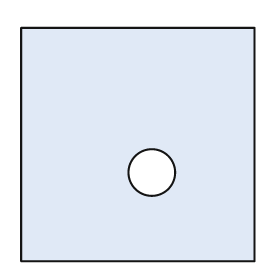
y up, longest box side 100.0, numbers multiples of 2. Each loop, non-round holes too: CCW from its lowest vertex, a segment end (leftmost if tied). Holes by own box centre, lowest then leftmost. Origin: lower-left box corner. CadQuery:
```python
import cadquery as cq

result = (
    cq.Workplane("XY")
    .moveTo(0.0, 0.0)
    .lineTo(100.0, 0.0)
    .lineTo(100.0, 100.0)
    .lineTo(0.0, 100.0)
    .close()
    .moveTo(56.0, 38.0)
    .circle(10.0)
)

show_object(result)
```